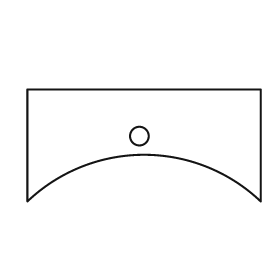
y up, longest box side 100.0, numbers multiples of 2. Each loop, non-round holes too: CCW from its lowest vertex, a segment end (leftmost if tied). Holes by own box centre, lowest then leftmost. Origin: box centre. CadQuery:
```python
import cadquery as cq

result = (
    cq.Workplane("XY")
    .moveTo(-50.0, -24.0)
    .threePointArc((0.0, -4.0), (50.0, -24.0))
    .lineTo(50.0, 24.0)
    .lineTo(-50.0, 24.0)
    .close()
    .moveTo(-2.0, 4.0)
    .circle(4.0)
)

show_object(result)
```